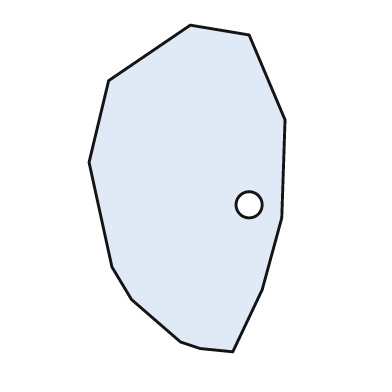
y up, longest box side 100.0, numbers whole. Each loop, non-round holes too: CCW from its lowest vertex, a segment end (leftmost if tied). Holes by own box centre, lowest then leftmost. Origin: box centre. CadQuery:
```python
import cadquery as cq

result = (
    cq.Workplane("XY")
    .moveTo(14.0, -50.0)
    .lineTo(23.0, -31.0)
    .lineTo(29.0, -9.0)
    .lineTo(30.0, 21.0)
    .lineTo(19.0, 47.0)
    .lineTo(1.0, 50.0)
    .lineTo(-24.0, 33.0)
    .lineTo(-30.0, 8.0)
    .lineTo(-23.0, -24.0)
    .lineTo(-17.0, -34.0)
    .lineTo(-2.0, -47.0)
    .lineTo(4.0, -49.0)
    .close()
    .moveTo(19.0, -5.0)
    .circle(4.0)
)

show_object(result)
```